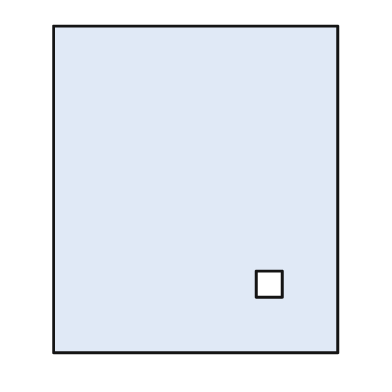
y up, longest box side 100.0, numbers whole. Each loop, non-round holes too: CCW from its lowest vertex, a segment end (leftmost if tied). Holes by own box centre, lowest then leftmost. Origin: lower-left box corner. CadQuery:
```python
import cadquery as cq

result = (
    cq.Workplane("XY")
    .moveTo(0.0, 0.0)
    .lineTo(87.0, 0.0)
    .lineTo(87.0, 100.0)
    .lineTo(0.0, 100.0)
    .close()
    .moveTo(62.0, 17.0)
    .lineTo(70.0, 17.0)
    .lineTo(70.0, 25.0)
    .lineTo(62.0, 25.0)
    .close()
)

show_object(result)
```